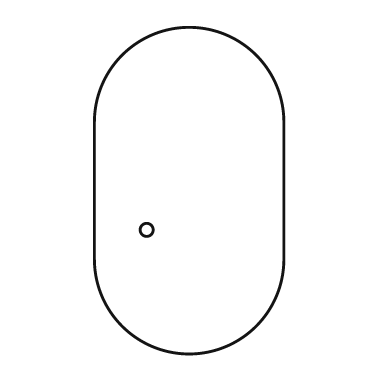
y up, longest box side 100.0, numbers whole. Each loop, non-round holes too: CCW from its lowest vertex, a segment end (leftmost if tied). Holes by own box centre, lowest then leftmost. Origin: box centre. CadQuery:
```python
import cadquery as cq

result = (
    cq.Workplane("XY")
    .moveTo(-29.0, -21.0)
    .threePointArc((0.0, -50.0), (29.0, -21.0))
    .lineTo(29.0, 21.0)
    .threePointArc((0.0, 50.0), (-29.0, 21.0))
    .close()
    .moveTo(-13.0, -12.0)
    .circle(2.0)
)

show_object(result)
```